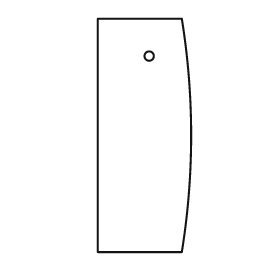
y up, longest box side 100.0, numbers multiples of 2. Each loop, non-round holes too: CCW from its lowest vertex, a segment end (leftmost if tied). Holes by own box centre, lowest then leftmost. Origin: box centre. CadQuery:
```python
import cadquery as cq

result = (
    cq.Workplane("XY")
    .moveTo(-20.0, -50.0)
    .lineTo(16.0, -50.0)
    .threePointArc((20.0, 0.0), (16.0, 50.0))
    .lineTo(-20.0, 50.0)
    .close()
    .moveTo(2.0, 34.0)
    .circle(2.0)
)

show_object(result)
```